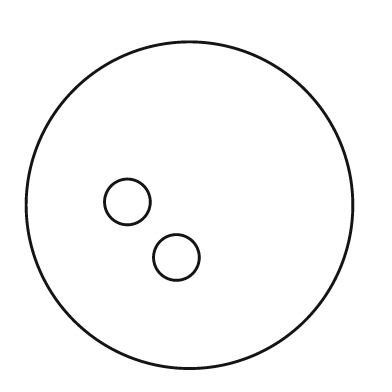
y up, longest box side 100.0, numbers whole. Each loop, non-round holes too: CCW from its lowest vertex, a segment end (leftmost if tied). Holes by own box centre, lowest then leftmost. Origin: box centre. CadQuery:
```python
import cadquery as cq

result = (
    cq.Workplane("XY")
    .moveTo(0.0, 0.0)
    .circle(50.0)
    .moveTo(-4.0, -16.0)
    .circle(7.0)
    .moveTo(-19.0, 1.0)
    .circle(7.0)
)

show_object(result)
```